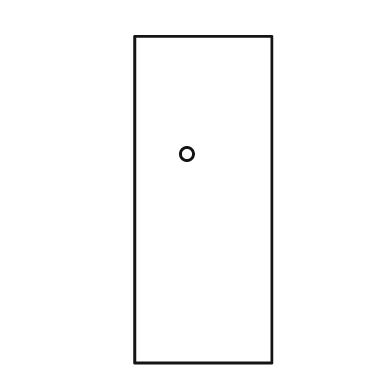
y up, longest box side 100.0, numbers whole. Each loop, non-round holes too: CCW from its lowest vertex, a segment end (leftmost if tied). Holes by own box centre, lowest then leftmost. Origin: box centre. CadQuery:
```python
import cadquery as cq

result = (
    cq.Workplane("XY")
    .moveTo(-21.0, -50.0)
    .lineTo(21.0, -50.0)
    .lineTo(21.0, 50.0)
    .lineTo(-21.0, 50.0)
    .close()
    .moveTo(-5.0, 14.0)
    .circle(2.0)
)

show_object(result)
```